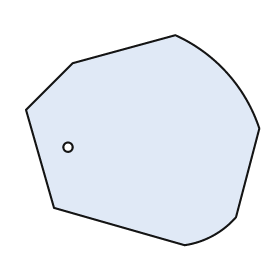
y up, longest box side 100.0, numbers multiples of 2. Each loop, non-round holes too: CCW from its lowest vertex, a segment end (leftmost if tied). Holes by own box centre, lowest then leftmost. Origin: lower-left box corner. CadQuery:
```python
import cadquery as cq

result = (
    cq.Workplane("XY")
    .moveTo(68.0, 0.0)
    .threePointArc((80.0, 4.0), (90.0, 12.0))
    .lineTo(100.0, 50.0)
    .threePointArc((86.0, 74.0), (64.0, 90.0))
    .lineTo(20.0, 78.0)
    .lineTo(0.0, 58.0)
    .lineTo(12.0, 16.0)
    .close()
    .moveTo(18.0, 42.0)
    .circle(2.0)
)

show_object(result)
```